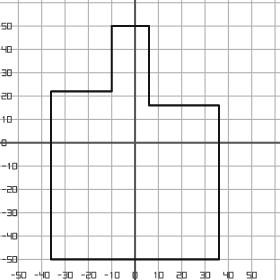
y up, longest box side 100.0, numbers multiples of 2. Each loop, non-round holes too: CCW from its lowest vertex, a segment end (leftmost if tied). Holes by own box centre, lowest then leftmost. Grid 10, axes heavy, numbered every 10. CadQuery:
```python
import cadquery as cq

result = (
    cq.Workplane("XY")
    .moveTo(-36.0, -50.0)
    .lineTo(36.0, -50.0)
    .lineTo(36.0, 16.0)
    .lineTo(6.0, 16.0)
    .lineTo(6.0, 50.0)
    .lineTo(-10.0, 50.0)
    .lineTo(-10.0, 22.0)
    .lineTo(-36.0, 22.0)
    .close()
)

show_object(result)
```